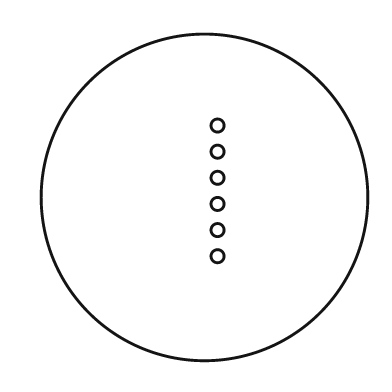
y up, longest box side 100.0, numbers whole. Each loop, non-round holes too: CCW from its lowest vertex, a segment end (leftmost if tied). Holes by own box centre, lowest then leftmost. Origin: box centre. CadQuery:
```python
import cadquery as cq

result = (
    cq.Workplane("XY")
    .moveTo(0.0, 0.0)
    .circle(50.0)
    .moveTo(4.0, -18.0)
    .circle(2.0)
    .moveTo(4.0, -10.0)
    .circle(2.0)
    .moveTo(4.0, -2.0)
    .circle(2.0)
    .moveTo(4.0, 6.0)
    .circle(2.0)
    .moveTo(4.0, 14.0)
    .circle(2.0)
    .moveTo(4.0, 22.0)
    .circle(2.0)
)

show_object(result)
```